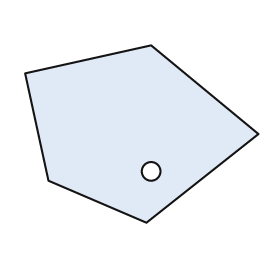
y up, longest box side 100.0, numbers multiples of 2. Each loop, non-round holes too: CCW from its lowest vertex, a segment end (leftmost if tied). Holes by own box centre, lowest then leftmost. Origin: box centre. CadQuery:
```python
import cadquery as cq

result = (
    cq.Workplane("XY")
    .moveTo(2.0, -38.0)
    .lineTo(50.0, 0.0)
    .lineTo(4.0, 38.0)
    .lineTo(-50.0, 26.0)
    .lineTo(-40.0, -20.0)
    .close()
    .moveTo(4.0, -16.0)
    .circle(4.0)
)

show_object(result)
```